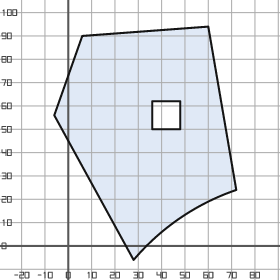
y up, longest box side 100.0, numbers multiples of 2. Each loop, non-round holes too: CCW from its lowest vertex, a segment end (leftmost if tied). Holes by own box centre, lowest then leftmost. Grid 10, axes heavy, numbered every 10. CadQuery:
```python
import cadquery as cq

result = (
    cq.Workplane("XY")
    .moveTo(28.0, -6.0)
    .threePointArc((48.0, 12.0), (72.0, 24.0))
    .lineTo(60.0, 94.0)
    .lineTo(6.0, 90.0)
    .lineTo(-6.0, 56.0)
    .close()
    .moveTo(36.0, 50.0)
    .lineTo(48.0, 50.0)
    .lineTo(48.0, 62.0)
    .lineTo(36.0, 62.0)
    .close()
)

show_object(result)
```